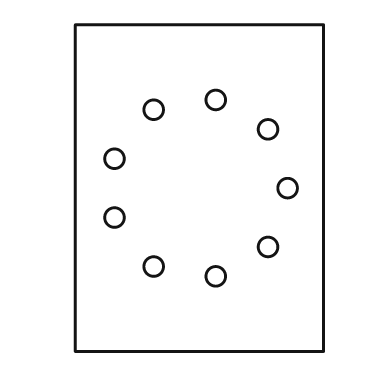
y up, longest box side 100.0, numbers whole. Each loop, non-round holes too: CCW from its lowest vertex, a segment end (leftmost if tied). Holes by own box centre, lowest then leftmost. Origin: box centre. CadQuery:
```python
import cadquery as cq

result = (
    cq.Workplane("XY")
    .moveTo(-38.0, -50.0)
    .lineTo(38.0, -50.0)
    .lineTo(38.0, 50.0)
    .lineTo(-38.0, 50.0)
    .close()
    .moveTo(5.0, -27.0)
    .circle(3.0)
    .moveTo(-14.0, -24.0)
    .circle(3.0)
    .moveTo(21.0, -18.0)
    .circle(3.0)
    .moveTo(-26.0, -9.0)
    .circle(3.0)
    .moveTo(27.0, 0.0)
    .circle(3.0)
    .moveTo(-26.0, 9.0)
    .circle(3.0)
    .moveTo(21.0, 18.0)
    .circle(3.0)
    .moveTo(-14.0, 24.0)
    .circle(3.0)
    .moveTo(5.0, 27.0)
    .circle(3.0)
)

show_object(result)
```